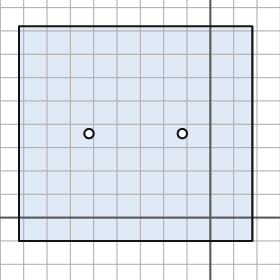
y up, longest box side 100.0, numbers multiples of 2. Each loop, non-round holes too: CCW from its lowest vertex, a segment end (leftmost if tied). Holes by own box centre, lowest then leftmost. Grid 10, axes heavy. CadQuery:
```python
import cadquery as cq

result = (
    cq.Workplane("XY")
    .moveTo(-82.0, -10.0)
    .lineTo(18.0, -10.0)
    .lineTo(18.0, 82.0)
    .lineTo(-82.0, 82.0)
    .close()
    .moveTo(-52.0, 36.0)
    .circle(2.0)
    .moveTo(-12.0, 36.0)
    .circle(2.0)
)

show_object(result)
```